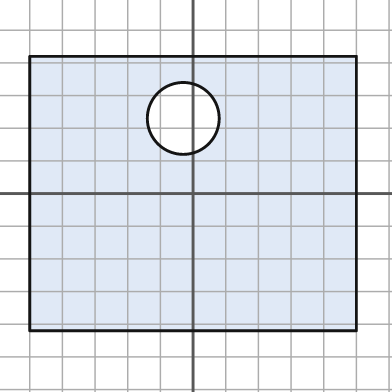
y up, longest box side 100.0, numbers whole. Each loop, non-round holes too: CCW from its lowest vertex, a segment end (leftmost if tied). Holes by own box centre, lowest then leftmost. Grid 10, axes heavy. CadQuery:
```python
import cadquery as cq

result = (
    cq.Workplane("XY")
    .moveTo(-50.0, -42.0)
    .lineTo(50.0, -42.0)
    .lineTo(50.0, 42.0)
    .lineTo(-50.0, 42.0)
    .close()
    .moveTo(-3.0, 23.0)
    .circle(11.0)
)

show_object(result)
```